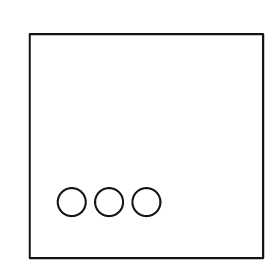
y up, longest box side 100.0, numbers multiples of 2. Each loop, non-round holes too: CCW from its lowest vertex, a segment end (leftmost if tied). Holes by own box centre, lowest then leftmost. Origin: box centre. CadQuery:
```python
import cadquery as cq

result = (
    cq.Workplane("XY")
    .moveTo(-50.0, -48.0)
    .lineTo(50.0, -48.0)
    .lineTo(50.0, 48.0)
    .lineTo(-50.0, 48.0)
    .close()
    .moveTo(-32.0, -24.0)
    .circle(6.0)
    .moveTo(-16.0, -24.0)
    .circle(6.0)
    .moveTo(0.0, -24.0)
    .circle(6.0)
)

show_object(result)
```